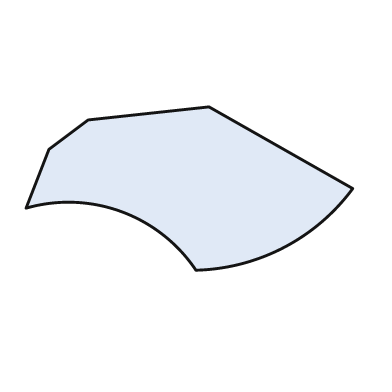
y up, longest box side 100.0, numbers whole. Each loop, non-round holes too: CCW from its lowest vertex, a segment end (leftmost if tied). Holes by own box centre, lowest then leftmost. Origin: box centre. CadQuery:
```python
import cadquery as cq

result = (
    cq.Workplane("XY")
    .moveTo(2.0, -25.0)
    .threePointArc((29.0, -18.0), (50.0, 0.0))
    .lineTo(6.0, 25.0)
    .lineTo(-31.0, 21.0)
    .lineTo(-43.0, 12.0)
    .lineTo(-50.0, -6.0)
    .threePointArc((-21.0, -7.0), (2.0, -25.0))
    .close()
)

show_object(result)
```